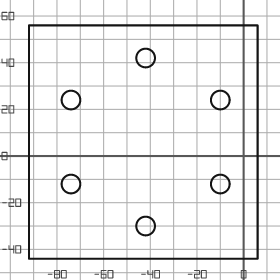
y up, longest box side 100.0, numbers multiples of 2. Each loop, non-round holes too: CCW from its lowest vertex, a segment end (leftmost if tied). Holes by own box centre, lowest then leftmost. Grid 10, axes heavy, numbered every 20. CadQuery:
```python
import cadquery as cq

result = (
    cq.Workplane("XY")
    .moveTo(-92.0, -44.0)
    .lineTo(6.0, -44.0)
    .lineTo(6.0, 56.0)
    .lineTo(-92.0, 56.0)
    .close()
    .moveTo(-42.0, -30.0)
    .circle(4.0)
    .moveTo(-74.0, -12.0)
    .circle(4.0)
    .moveTo(-10.0, -12.0)
    .circle(4.0)
    .moveTo(-74.0, 24.0)
    .circle(4.0)
    .moveTo(-10.0, 24.0)
    .circle(4.0)
    .moveTo(-42.0, 42.0)
    .circle(4.0)
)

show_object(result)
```